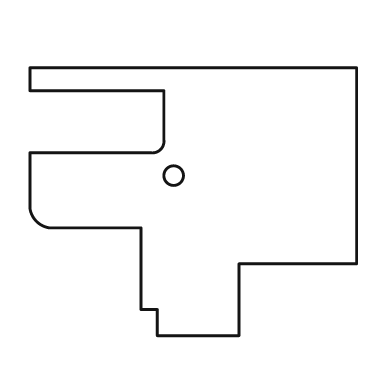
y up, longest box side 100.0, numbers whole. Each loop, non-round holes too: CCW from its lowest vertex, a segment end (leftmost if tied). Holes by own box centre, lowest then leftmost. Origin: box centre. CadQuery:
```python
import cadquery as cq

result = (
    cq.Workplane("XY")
    .moveTo(-11.0, -41.0)
    .lineTo(14.0, -41.0)
    .lineTo(14.0, -19.0)
    .lineTo(50.0, -19.0)
    .lineTo(50.0, 41.0)
    .lineTo(-50.0, 41.0)
    .lineTo(-50.0, 34.0)
    .lineTo(-9.0, 34.0)
    .lineTo(-9.0, 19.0)
    .threePointArc((-10.0, 16.0), (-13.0, 15.0))
    .lineTo(-50.0, 15.0)
    .lineTo(-50.0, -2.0)
    .threePointArc((-48.0, -6.0), (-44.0, -8.0))
    .lineTo(-16.0, -8.0)
    .lineTo(-16.0, -33.0)
    .lineTo(-11.0, -33.0)
    .close()
    .moveTo(-6.0, 8.0)
    .circle(3.0)
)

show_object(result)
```